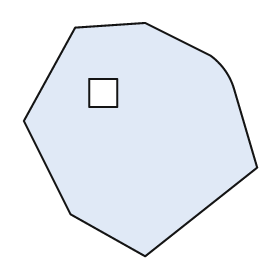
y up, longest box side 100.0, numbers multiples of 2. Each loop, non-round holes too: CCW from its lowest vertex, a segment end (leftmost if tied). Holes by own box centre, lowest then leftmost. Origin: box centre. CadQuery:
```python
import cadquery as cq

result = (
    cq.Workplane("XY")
    .moveTo(2.0, -50.0)
    .lineTo(50.0, -12.0)
    .lineTo(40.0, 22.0)
    .threePointArc((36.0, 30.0), (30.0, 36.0))
    .lineTo(2.0, 50.0)
    .lineTo(-28.0, 48.0)
    .lineTo(-50.0, 8.0)
    .lineTo(-30.0, -32.0)
    .close()
    .moveTo(-22.0, 14.0)
    .lineTo(-10.0, 14.0)
    .lineTo(-10.0, 26.0)
    .lineTo(-22.0, 26.0)
    .close()
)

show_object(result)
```